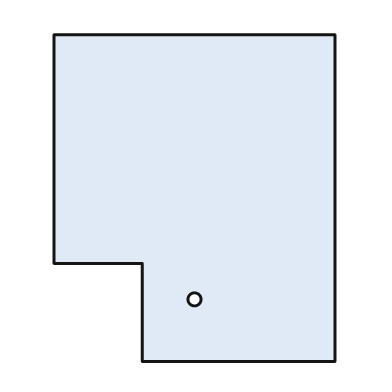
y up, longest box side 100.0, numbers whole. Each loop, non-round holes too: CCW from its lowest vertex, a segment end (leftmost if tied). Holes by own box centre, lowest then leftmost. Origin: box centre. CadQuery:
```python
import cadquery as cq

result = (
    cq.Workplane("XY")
    .moveTo(-16.0, -50.0)
    .lineTo(43.0, -50.0)
    .lineTo(43.0, 50.0)
    .lineTo(-43.0, 50.0)
    .lineTo(-43.0, -20.0)
    .lineTo(-16.0, -20.0)
    .close()
    .moveTo(0.0, -31.0)
    .circle(2.0)
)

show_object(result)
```